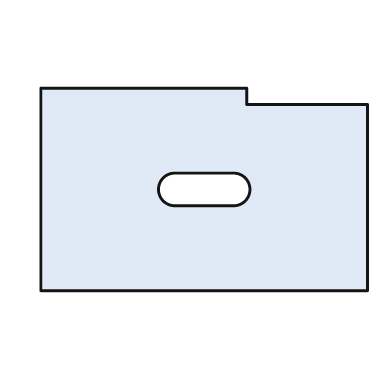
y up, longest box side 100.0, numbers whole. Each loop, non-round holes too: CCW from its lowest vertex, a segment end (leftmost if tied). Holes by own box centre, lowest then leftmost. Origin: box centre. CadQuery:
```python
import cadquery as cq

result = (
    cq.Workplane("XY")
    .moveTo(-50.0, -31.0)
    .lineTo(50.0, -31.0)
    .lineTo(50.0, 26.0)
    .lineTo(13.0, 26.0)
    .lineTo(13.0, 31.0)
    .lineTo(-50.0, 31.0)
    .close()
    .moveTo(-9.0, -5.0)
    .lineTo(9.0, -5.0)
    .threePointArc((14.0, 0.0), (9.0, 5.0))
    .lineTo(-9.0, 5.0)
    .threePointArc((-14.0, 0.0), (-9.0, -5.0))
    .close()
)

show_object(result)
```